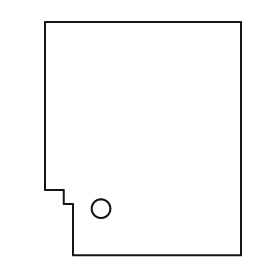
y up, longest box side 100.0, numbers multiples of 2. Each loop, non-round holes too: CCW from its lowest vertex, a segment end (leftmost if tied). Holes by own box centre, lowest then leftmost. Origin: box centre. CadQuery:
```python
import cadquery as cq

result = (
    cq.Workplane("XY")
    .moveTo(-30.0, -50.0)
    .lineTo(42.0, -50.0)
    .lineTo(42.0, 50.0)
    .lineTo(-42.0, 50.0)
    .lineTo(-42.0, -22.0)
    .lineTo(-34.0, -22.0)
    .lineTo(-34.0, -28.0)
    .lineTo(-30.0, -28.0)
    .close()
    .moveTo(-18.0, -30.0)
    .circle(4.0)
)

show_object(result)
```